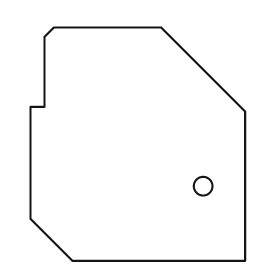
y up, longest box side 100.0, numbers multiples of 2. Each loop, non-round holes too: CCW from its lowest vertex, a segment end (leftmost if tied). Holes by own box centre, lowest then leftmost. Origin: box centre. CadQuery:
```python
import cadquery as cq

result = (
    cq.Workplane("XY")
    .moveTo(-28.0, -50.0)
    .lineTo(46.0, -50.0)
    .lineTo(46.0, 14.0)
    .lineTo(10.0, 50.0)
    .lineTo(-36.0, 50.0)
    .lineTo(-40.0, 46.0)
    .lineTo(-40.0, 16.0)
    .lineTo(-46.0, 16.0)
    .lineTo(-46.0, -32.0)
    .close()
    .moveTo(28.0, -18.0)
    .circle(4.0)
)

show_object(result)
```